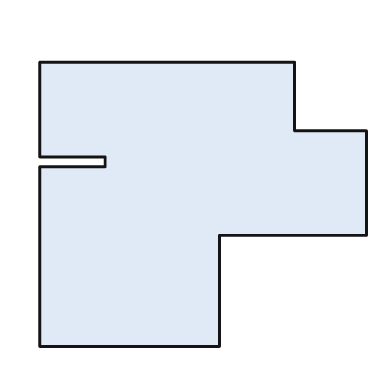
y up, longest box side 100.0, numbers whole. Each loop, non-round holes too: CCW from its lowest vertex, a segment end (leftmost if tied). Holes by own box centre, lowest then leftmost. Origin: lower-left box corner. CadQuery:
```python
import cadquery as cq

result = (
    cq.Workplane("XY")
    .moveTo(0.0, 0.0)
    .lineTo(55.0, 0.0)
    .lineTo(55.0, 34.0)
    .lineTo(100.0, 34.0)
    .lineTo(100.0, 66.0)
    .lineTo(78.0, 66.0)
    .lineTo(78.0, 87.0)
    .lineTo(0.0, 87.0)
    .lineTo(0.0, 58.0)
    .lineTo(20.0, 58.0)
    .lineTo(20.0, 55.0)
    .lineTo(0.0, 55.0)
    .close()
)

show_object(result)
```